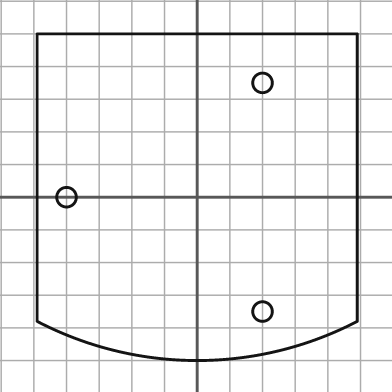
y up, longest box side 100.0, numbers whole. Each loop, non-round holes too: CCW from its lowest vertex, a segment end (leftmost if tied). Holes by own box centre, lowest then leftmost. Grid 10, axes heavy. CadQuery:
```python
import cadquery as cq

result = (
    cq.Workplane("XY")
    .moveTo(-49.0, -38.0)
    .threePointArc((0.0, -50.0), (49.0, -38.0))
    .lineTo(49.0, 50.0)
    .lineTo(-49.0, 50.0)
    .close()
    .moveTo(20.0, -35.0)
    .circle(3.0)
    .moveTo(-40.0, 0.0)
    .circle(3.0)
    .moveTo(20.0, 35.0)
    .circle(3.0)
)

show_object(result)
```